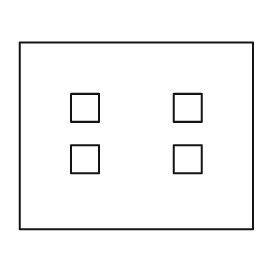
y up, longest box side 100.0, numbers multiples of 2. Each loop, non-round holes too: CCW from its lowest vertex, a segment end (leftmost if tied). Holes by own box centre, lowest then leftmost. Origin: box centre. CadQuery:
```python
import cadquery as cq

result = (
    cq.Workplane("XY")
    .moveTo(-50.0, -40.0)
    .lineTo(50.0, -40.0)
    .lineTo(50.0, 40.0)
    .lineTo(-50.0, 40.0)
    .close()
    .moveTo(-28.0, -16.0)
    .lineTo(-16.0, -16.0)
    .lineTo(-16.0, -4.0)
    .lineTo(-28.0, -4.0)
    .close()
    .moveTo(16.0, -16.0)
    .lineTo(28.0, -16.0)
    .lineTo(28.0, -4.0)
    .lineTo(16.0, -4.0)
    .close()
    .moveTo(-28.0, 6.0)
    .lineTo(-16.0, 6.0)
    .lineTo(-16.0, 18.0)
    .lineTo(-28.0, 18.0)
    .close()
    .moveTo(16.0, 6.0)
    .lineTo(28.0, 6.0)
    .lineTo(28.0, 18.0)
    .lineTo(16.0, 18.0)
    .close()
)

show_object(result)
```